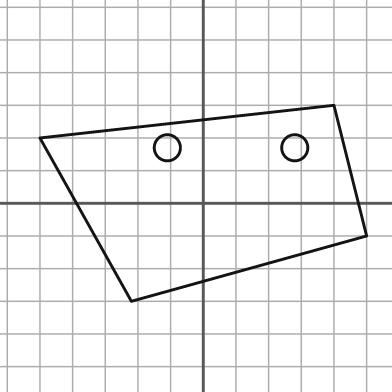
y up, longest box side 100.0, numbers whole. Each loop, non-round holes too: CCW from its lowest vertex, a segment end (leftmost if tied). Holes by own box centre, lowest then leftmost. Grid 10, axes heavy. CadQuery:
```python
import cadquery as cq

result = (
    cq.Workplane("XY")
    .moveTo(-22.0, -30.0)
    .lineTo(50.0, -10.0)
    .lineTo(40.0, 30.0)
    .lineTo(-50.0, 20.0)
    .close()
    .moveTo(-11.0, 17.0)
    .circle(4.0)
    .moveTo(28.0, 17.0)
    .circle(4.0)
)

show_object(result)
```